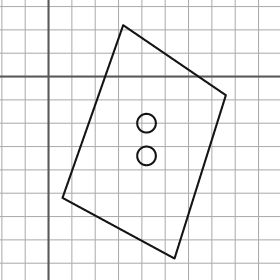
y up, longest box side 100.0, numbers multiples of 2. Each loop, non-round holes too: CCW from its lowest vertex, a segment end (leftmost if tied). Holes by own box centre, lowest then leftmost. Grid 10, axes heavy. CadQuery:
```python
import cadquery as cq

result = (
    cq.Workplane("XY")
    .moveTo(54.0, -78.0)
    .lineTo(76.0, -8.0)
    .lineTo(32.0, 22.0)
    .lineTo(6.0, -52.0)
    .close()
    .moveTo(42.0, -34.0)
    .circle(4.0)
    .moveTo(42.0, -20.0)
    .circle(4.0)
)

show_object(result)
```